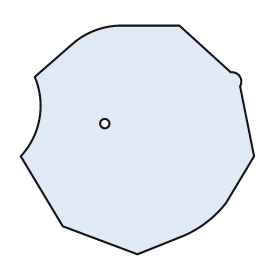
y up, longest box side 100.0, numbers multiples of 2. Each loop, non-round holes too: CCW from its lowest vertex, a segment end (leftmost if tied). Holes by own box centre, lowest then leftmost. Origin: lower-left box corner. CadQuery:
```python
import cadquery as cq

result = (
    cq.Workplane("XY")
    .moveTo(50.0, 0.0)
    .lineTo(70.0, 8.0)
    .threePointArc((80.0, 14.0), (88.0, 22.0))
    .lineTo(100.0, 42.0)
    .lineTo(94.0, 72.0)
    .threePointArc((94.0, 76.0), (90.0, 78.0))
    .lineTo(68.0, 98.0)
    .lineTo(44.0, 98.0)
    .threePointArc((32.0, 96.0), (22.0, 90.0))
    .lineTo(6.0, 76.0)
    .threePointArc((8.0, 58.0), (0.0, 42.0))
    .lineTo(18.0, 12.0)
    .close()
    .moveTo(36.0, 56.0)
    .circle(2.0)
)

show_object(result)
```